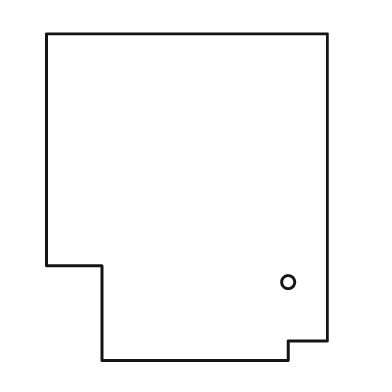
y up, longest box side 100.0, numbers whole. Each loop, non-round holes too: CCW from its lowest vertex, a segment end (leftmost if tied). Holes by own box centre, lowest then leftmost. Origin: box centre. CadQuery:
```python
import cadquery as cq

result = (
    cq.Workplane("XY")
    .moveTo(-26.0, -50.0)
    .lineTo(31.0, -50.0)
    .lineTo(31.0, -44.0)
    .lineTo(43.0, -44.0)
    .lineTo(43.0, 50.0)
    .lineTo(-43.0, 50.0)
    .lineTo(-43.0, -21.0)
    .lineTo(-26.0, -21.0)
    .close()
    .moveTo(31.0, -26.0)
    .circle(2.0)
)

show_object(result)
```